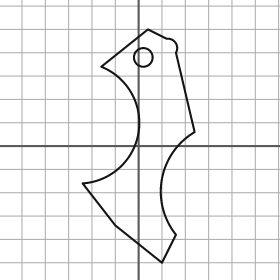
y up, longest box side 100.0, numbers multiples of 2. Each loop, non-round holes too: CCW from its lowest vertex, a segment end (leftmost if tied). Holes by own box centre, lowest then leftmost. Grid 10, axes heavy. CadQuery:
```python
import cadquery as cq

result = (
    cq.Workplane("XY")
    .moveTo(10.0, -50.0)
    .lineTo(16.0, -38.0)
    .threePointArc((10.0, -14.0), (24.0, 6.0))
    .lineTo(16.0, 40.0)
    .threePointArc((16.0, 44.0), (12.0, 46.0))
    .lineTo(4.0, 50.0)
    .lineTo(-16.0, 34.0)
    .threePointArc((0.0, 6.0), (-24.0, -16.0))
    .lineTo(-10.0, -34.0)
    .close()
    .moveTo(2.0, 38.0)
    .circle(4.0)
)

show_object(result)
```